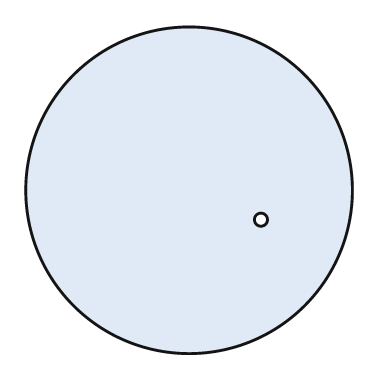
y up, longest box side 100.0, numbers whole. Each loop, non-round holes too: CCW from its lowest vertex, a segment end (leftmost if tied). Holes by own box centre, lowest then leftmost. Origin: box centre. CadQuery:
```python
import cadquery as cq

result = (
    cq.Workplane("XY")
    .moveTo(0.0, 0.0)
    .circle(50.0)
    .moveTo(22.0, -9.0)
    .circle(2.0)
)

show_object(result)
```